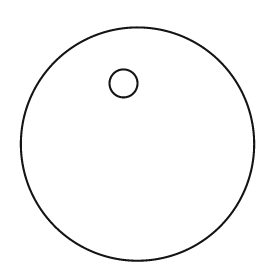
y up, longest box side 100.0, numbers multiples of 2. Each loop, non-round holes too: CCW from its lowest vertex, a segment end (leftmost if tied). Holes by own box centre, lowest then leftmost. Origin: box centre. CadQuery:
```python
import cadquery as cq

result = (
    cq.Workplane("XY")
    .moveTo(0.0, 0.0)
    .circle(50.0)
    .moveTo(-6.0, 26.0)
    .circle(6.0)
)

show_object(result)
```